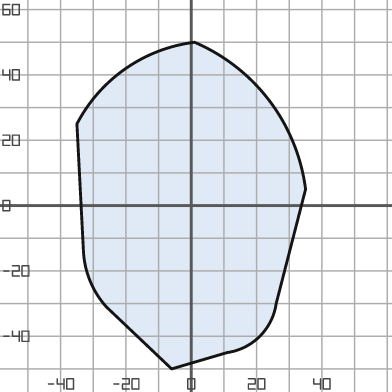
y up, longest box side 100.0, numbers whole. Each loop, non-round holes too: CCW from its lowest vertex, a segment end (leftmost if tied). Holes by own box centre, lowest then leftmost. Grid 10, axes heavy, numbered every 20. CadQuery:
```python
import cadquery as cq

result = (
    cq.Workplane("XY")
    .moveTo(-6.0, -50.0)
    .lineTo(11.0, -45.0)
    .threePointArc((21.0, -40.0), (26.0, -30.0))
    .lineTo(35.0, 5.0)
    .threePointArc((24.0, 32.0), (1.0, 50.0))
    .threePointArc((-20.0, 42.0), (-35.0, 25.0))
    .lineTo(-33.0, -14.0)
    .threePointArc((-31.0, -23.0), (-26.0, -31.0))
    .close()
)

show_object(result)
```